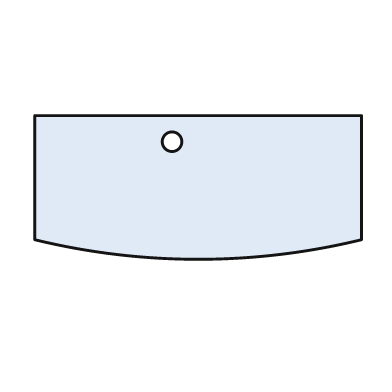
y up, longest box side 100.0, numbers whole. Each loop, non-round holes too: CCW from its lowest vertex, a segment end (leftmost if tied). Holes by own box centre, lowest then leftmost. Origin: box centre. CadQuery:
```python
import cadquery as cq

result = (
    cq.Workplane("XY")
    .moveTo(-50.0, -16.0)
    .threePointArc((0.0, -22.0), (50.0, -16.0))
    .lineTo(50.0, 22.0)
    .lineTo(-50.0, 22.0)
    .close()
    .moveTo(-8.0, 14.0)
    .circle(3.0)
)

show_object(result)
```